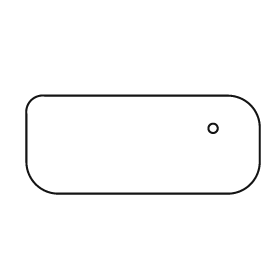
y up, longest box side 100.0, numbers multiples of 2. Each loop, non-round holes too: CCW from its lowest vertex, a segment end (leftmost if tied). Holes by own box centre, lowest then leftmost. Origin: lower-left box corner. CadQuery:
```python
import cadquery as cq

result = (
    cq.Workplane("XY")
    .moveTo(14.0, 0.0)
    .lineTo(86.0, 0.0)
    .threePointArc((96.0, 4.0), (100.0, 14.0))
    .lineTo(100.0, 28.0)
    .threePointArc((96.0, 38.0), (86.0, 42.0))
    .lineTo(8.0, 42.0)
    .threePointArc((2.0, 40.0), (0.0, 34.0))
    .lineTo(0.0, 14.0)
    .threePointArc((4.0, 4.0), (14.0, 0.0))
    .close()
    .moveTo(80.0, 28.0)
    .circle(2.0)
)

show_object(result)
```